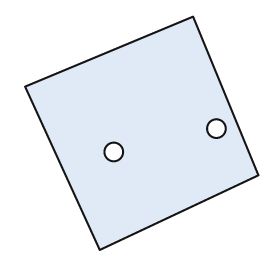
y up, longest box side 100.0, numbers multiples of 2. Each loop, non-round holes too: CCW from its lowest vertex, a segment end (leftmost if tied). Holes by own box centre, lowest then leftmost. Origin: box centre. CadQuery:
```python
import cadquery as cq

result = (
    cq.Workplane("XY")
    .moveTo(-18.0, -50.0)
    .lineTo(50.0, -18.0)
    .lineTo(22.0, 50.0)
    .lineTo(-50.0, 20.0)
    .close()
    .moveTo(-12.0, -8.0)
    .circle(4.0)
    .moveTo(32.0, 2.0)
    .circle(4.0)
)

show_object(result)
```